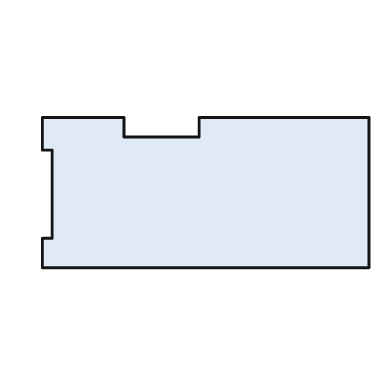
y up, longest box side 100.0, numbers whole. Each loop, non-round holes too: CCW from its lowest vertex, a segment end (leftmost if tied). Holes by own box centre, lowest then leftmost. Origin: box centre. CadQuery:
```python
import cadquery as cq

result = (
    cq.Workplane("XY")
    .moveTo(-50.0, -23.0)
    .lineTo(50.0, -23.0)
    .lineTo(50.0, 23.0)
    .lineTo(-2.0, 23.0)
    .lineTo(-2.0, 17.0)
    .lineTo(-25.0, 17.0)
    .lineTo(-25.0, 23.0)
    .lineTo(-50.0, 23.0)
    .lineTo(-50.0, 13.0)
    .lineTo(-47.0, 13.0)
    .lineTo(-47.0, -14.0)
    .lineTo(-50.0, -14.0)
    .close()
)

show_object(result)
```